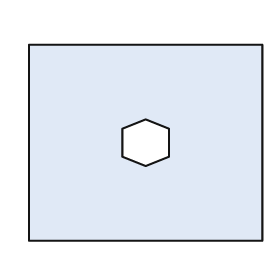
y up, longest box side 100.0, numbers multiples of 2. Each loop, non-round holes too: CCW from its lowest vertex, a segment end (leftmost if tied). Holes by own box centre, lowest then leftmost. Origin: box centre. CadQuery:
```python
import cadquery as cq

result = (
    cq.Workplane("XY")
    .moveTo(-50.0, -42.0)
    .lineTo(50.0, -42.0)
    .lineTo(50.0, 42.0)
    .lineTo(-50.0, 42.0)
    .close()
    .moveTo(0.0, -10.0)
    .lineTo(10.0, -6.0)
    .lineTo(10.0, 6.0)
    .lineTo(0.0, 10.0)
    .lineTo(-10.0, 6.0)
    .lineTo(-10.0, -6.0)
    .close()
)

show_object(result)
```